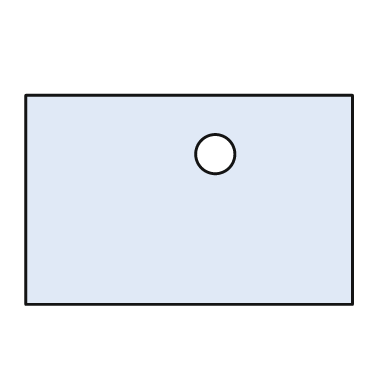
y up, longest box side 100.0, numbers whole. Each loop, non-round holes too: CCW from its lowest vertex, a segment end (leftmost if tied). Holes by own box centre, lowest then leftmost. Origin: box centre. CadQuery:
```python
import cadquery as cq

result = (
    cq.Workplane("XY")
    .moveTo(-50.0, -32.0)
    .lineTo(50.0, -32.0)
    .lineTo(50.0, 32.0)
    .lineTo(-50.0, 32.0)
    .close()
    .moveTo(8.0, 14.0)
    .circle(6.0)
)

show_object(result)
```